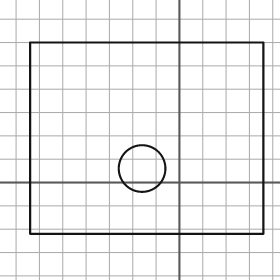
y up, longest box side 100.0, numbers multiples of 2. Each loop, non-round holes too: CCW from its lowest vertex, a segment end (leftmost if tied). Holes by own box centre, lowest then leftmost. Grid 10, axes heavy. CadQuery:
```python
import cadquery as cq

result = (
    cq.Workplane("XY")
    .moveTo(-64.0, -22.0)
    .lineTo(36.0, -22.0)
    .lineTo(36.0, 60.0)
    .lineTo(-64.0, 60.0)
    .close()
    .moveTo(-16.0, 6.0)
    .circle(10.0)
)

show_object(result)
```